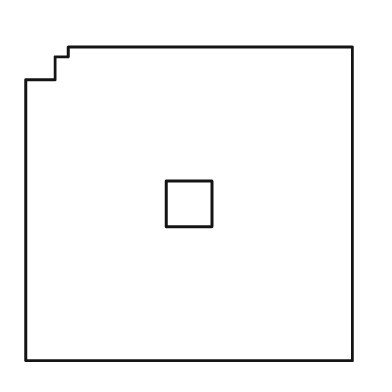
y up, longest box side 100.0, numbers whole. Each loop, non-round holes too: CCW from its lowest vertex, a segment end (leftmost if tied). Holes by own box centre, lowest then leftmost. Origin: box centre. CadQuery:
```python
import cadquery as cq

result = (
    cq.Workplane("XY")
    .moveTo(-50.0, -48.0)
    .lineTo(50.0, -48.0)
    .lineTo(50.0, 48.0)
    .lineTo(-37.0, 48.0)
    .lineTo(-37.0, 45.0)
    .lineTo(-41.0, 45.0)
    .lineTo(-41.0, 38.0)
    .lineTo(-50.0, 38.0)
    .close()
    .moveTo(-7.0, -7.0)
    .lineTo(7.0, -7.0)
    .lineTo(7.0, 7.0)
    .lineTo(-7.0, 7.0)
    .close()
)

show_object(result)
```